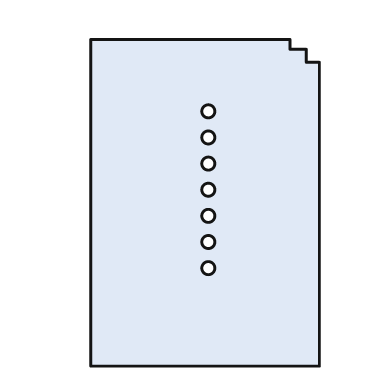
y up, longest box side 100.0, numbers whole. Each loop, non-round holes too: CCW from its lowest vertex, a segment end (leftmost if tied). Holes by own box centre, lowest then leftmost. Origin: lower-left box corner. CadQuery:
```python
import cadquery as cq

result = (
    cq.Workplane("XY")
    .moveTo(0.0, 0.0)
    .lineTo(70.0, 0.0)
    .lineTo(70.0, 93.0)
    .lineTo(66.0, 93.0)
    .lineTo(66.0, 97.0)
    .lineTo(61.0, 97.0)
    .lineTo(61.0, 100.0)
    .lineTo(0.0, 100.0)
    .close()
    .moveTo(36.0, 30.0)
    .circle(2.0)
    .moveTo(36.0, 38.0)
    .circle(2.0)
    .moveTo(36.0, 46.0)
    .circle(2.0)
    .moveTo(36.0, 54.0)
    .circle(2.0)
    .moveTo(36.0, 62.0)
    .circle(2.0)
    .moveTo(36.0, 70.0)
    .circle(2.0)
    .moveTo(36.0, 78.0)
    .circle(2.0)
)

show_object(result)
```